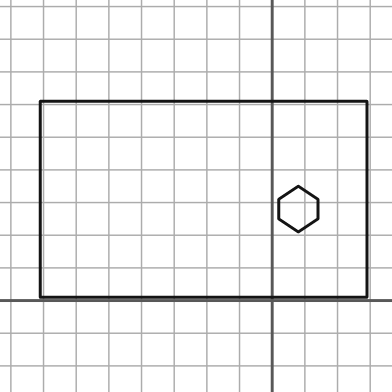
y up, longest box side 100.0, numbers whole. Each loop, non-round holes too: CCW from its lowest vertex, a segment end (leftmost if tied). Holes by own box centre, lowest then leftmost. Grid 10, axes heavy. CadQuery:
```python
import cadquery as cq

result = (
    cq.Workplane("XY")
    .moveTo(-71.0, 1.0)
    .lineTo(29.0, 1.0)
    .lineTo(29.0, 61.0)
    .lineTo(-71.0, 61.0)
    .close()
    .moveTo(8.0, 21.0)
    .lineTo(14.0, 25.0)
    .lineTo(14.0, 31.0)
    .lineTo(8.0, 35.0)
    .lineTo(2.0, 31.0)
    .lineTo(2.0, 25.0)
    .close()
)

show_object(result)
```